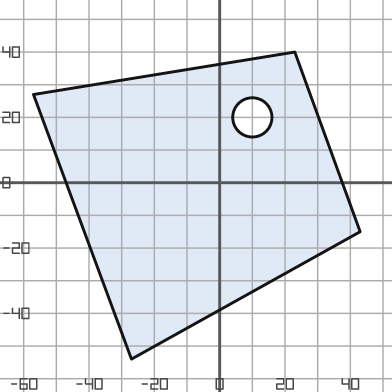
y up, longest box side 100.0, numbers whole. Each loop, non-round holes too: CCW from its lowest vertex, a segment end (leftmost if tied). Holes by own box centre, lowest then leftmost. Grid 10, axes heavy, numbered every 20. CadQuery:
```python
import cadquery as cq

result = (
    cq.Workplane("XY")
    .moveTo(-27.0, -54.0)
    .lineTo(43.0, -15.0)
    .lineTo(23.0, 40.0)
    .lineTo(-57.0, 27.0)
    .close()
    .moveTo(10.0, 20.0)
    .circle(6.0)
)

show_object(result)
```